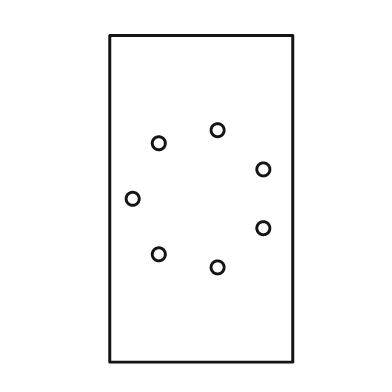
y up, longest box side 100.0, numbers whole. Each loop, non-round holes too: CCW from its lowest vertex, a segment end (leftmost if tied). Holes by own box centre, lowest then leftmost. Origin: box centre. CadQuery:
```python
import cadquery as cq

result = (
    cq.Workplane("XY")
    .moveTo(-28.0, -50.0)
    .lineTo(28.0, -50.0)
    .lineTo(28.0, 50.0)
    .lineTo(-28.0, 50.0)
    .close()
    .moveTo(5.0, -21.0)
    .circle(2.0)
    .moveTo(-13.0, -17.0)
    .circle(2.0)
    .moveTo(19.0, -9.0)
    .circle(2.0)
    .moveTo(-21.0, 0.0)
    .circle(2.0)
    .moveTo(19.0, 9.0)
    .circle(2.0)
    .moveTo(-13.0, 17.0)
    .circle(2.0)
    .moveTo(5.0, 21.0)
    .circle(2.0)
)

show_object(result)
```